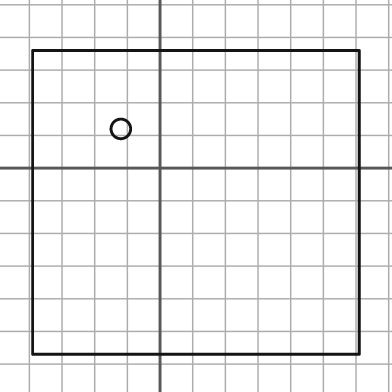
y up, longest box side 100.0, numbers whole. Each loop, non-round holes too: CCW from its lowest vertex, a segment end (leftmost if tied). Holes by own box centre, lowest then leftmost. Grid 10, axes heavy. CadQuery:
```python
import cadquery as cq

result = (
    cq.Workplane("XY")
    .moveTo(-39.0, -57.0)
    .lineTo(61.0, -57.0)
    .lineTo(61.0, 36.0)
    .lineTo(-39.0, 36.0)
    .close()
    .moveTo(-12.0, 12.0)
    .circle(3.0)
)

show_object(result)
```